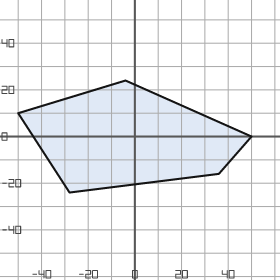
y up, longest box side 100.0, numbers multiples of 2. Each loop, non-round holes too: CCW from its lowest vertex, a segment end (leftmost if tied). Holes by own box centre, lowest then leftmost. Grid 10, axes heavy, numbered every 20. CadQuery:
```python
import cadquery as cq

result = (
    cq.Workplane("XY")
    .moveTo(-28.0, -24.0)
    .lineTo(36.0, -16.0)
    .lineTo(50.0, 0.0)
    .lineTo(-4.0, 24.0)
    .lineTo(-50.0, 10.0)
    .close()
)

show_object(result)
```